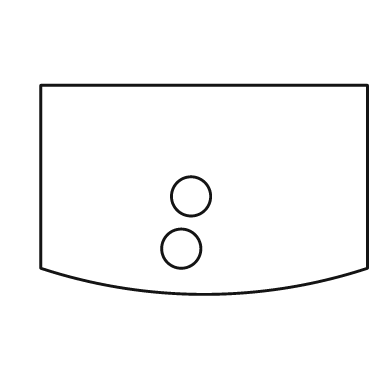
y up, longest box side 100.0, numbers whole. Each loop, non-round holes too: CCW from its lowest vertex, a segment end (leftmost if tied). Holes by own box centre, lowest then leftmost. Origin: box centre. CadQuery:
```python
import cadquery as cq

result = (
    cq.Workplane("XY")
    .moveTo(-50.0, -24.0)
    .threePointArc((0.0, -32.0), (50.0, -24.0))
    .lineTo(50.0, 32.0)
    .lineTo(-50.0, 32.0)
    .close()
    .moveTo(-7.0, -18.0)
    .circle(6.0)
    .moveTo(-4.0, -2.0)
    .circle(6.0)
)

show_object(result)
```